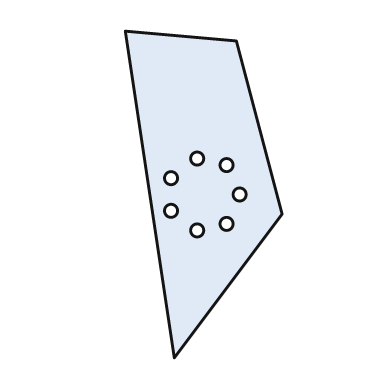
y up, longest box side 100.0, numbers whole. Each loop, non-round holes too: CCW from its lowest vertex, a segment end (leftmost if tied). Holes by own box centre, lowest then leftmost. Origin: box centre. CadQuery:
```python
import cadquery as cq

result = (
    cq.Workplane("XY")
    .moveTo(-9.0, -50.0)
    .lineTo(24.0, -6.0)
    .lineTo(10.0, 47.0)
    .lineTo(-24.0, 50.0)
    .close()
    .moveTo(-2.0, -11.0)
    .circle(2.0)
    .moveTo(7.0, -9.0)
    .circle(2.0)
    .moveTo(-10.0, -5.0)
    .circle(2.0)
    .moveTo(11.0, 0.0)
    .circle(2.0)
    .moveTo(-10.0, 5.0)
    .circle(2.0)
    .moveTo(7.0, 9.0)
    .circle(2.0)
    .moveTo(-2.0, 11.0)
    .circle(2.0)
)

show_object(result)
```